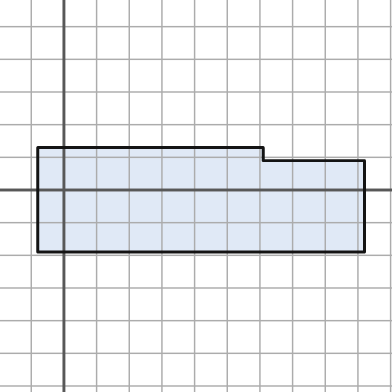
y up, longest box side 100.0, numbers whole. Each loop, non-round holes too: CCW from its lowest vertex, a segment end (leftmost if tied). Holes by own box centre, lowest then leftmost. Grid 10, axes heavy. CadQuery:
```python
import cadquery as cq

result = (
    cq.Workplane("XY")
    .moveTo(-8.0, -19.0)
    .lineTo(92.0, -19.0)
    .lineTo(92.0, 9.0)
    .lineTo(61.0, 9.0)
    .lineTo(61.0, 13.0)
    .lineTo(-8.0, 13.0)
    .close()
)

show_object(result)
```